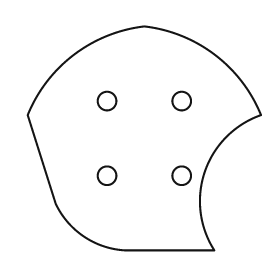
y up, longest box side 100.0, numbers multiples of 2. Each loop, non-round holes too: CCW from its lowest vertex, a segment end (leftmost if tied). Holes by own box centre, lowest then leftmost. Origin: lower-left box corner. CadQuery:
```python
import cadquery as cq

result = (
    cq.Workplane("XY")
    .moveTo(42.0, 0.0)
    .lineTo(80.0, 0.0)
    .threePointArc((76.0, 34.0), (100.0, 58.0))
    .threePointArc((80.0, 84.0), (50.0, 96.0))
    .threePointArc((20.0, 84.0), (0.0, 58.0))
    .lineTo(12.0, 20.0)
    .threePointArc((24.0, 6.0), (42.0, 0.0))
    .close()
    .moveTo(34.0, 32.0)
    .circle(4.0)
    .moveTo(66.0, 32.0)
    .circle(4.0)
    .moveTo(34.0, 64.0)
    .circle(4.0)
    .moveTo(66.0, 64.0)
    .circle(4.0)
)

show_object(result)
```